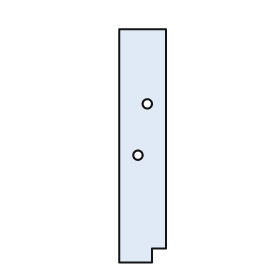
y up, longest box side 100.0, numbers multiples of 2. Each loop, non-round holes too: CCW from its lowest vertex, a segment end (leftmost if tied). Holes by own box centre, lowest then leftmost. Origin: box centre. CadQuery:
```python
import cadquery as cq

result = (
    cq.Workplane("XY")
    .moveTo(-10.0, -50.0)
    .lineTo(4.0, -50.0)
    .lineTo(4.0, -44.0)
    .lineTo(10.0, -44.0)
    .lineTo(10.0, 50.0)
    .lineTo(-10.0, 50.0)
    .close()
    .moveTo(-2.0, -4.0)
    .circle(2.0)
    .moveTo(2.0, 18.0)
    .circle(2.0)
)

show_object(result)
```